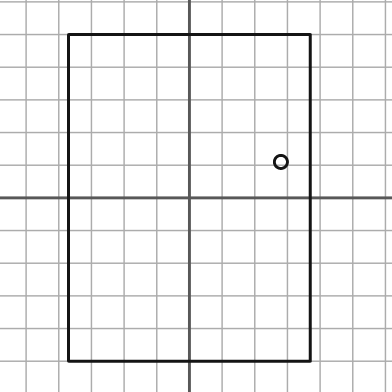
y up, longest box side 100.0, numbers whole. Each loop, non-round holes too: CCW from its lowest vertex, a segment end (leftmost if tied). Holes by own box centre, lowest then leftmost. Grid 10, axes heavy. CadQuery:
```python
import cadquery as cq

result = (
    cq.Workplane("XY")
    .moveTo(-37.0, -50.0)
    .lineTo(37.0, -50.0)
    .lineTo(37.0, 50.0)
    .lineTo(-37.0, 50.0)
    .close()
    .moveTo(28.0, 11.0)
    .circle(2.0)
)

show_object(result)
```